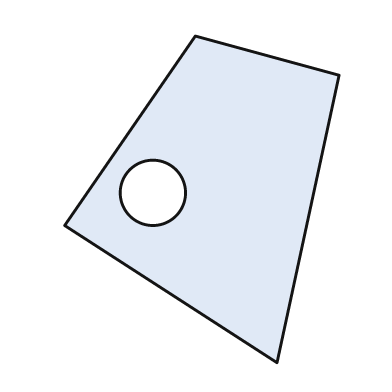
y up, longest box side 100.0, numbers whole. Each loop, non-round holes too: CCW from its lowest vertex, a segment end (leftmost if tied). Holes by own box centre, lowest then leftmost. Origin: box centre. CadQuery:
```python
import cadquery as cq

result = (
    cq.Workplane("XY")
    .moveTo(23.0, -50.0)
    .lineTo(42.0, 38.0)
    .lineTo(-2.0, 50.0)
    .lineTo(-42.0, -8.0)
    .close()
    .moveTo(-15.0, 2.0)
    .circle(10.0)
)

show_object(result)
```